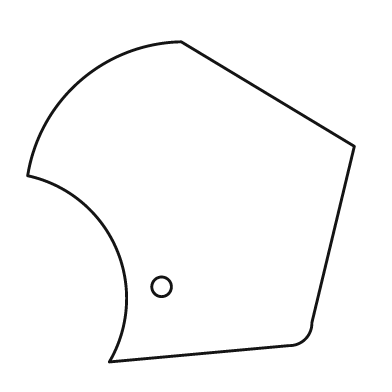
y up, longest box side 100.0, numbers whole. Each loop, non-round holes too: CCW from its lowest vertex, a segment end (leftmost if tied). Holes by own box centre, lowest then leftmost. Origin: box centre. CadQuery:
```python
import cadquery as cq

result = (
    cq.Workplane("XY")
    .moveTo(-25.0, -49.0)
    .lineTo(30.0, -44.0)
    .threePointArc((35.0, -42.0), (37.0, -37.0))
    .lineTo(50.0, 17.0)
    .lineTo(-3.0, 49.0)
    .threePointArc((-34.0, 37.0), (-50.0, 8.0))
    .threePointArc((-23.0, -14.0), (-25.0, -49.0))
    .close()
    .moveTo(-9.0, -26.0)
    .circle(3.0)
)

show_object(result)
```